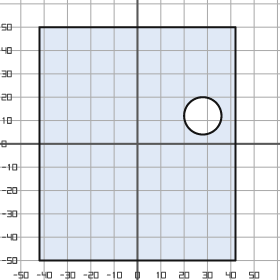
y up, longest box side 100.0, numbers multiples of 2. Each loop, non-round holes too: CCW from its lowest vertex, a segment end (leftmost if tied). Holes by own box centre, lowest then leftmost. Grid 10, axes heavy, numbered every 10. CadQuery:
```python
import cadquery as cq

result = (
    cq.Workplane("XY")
    .moveTo(-42.0, -50.0)
    .lineTo(42.0, -50.0)
    .lineTo(42.0, 50.0)
    .lineTo(-42.0, 50.0)
    .close()
    .moveTo(28.0, 12.0)
    .circle(8.0)
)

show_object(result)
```